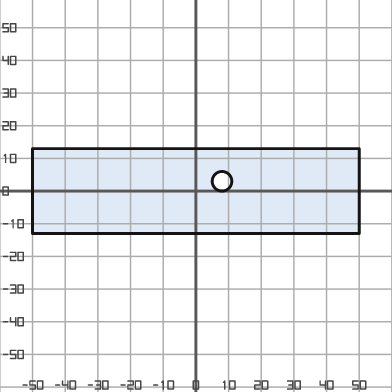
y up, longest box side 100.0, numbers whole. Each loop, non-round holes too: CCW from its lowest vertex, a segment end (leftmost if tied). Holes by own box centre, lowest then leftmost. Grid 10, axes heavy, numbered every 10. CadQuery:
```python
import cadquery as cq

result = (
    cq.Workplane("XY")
    .moveTo(-50.0, -13.0)
    .lineTo(50.0, -13.0)
    .lineTo(50.0, 13.0)
    .lineTo(-50.0, 13.0)
    .close()
    .moveTo(8.0, 3.0)
    .circle(3.0)
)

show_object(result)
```